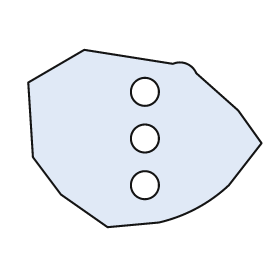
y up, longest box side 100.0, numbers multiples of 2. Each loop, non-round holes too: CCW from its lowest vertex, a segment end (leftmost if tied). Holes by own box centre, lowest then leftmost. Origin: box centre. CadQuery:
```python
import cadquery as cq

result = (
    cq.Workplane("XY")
    .moveTo(-16.0, -38.0)
    .lineTo(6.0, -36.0)
    .threePointArc((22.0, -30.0), (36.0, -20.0))
    .lineTo(50.0, -2.0)
    .lineTo(40.0, 12.0)
    .lineTo(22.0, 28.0)
    .threePointArc((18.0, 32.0), (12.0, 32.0))
    .lineTo(-26.0, 38.0)
    .lineTo(-50.0, 24.0)
    .lineTo(-48.0, -8.0)
    .lineTo(-36.0, -24.0)
    .close()
    .moveTo(0.0, -20.0)
    .circle(6.0)
    .moveTo(0.0, 0.0)
    .circle(6.0)
    .moveTo(0.0, 20.0)
    .circle(6.0)
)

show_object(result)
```